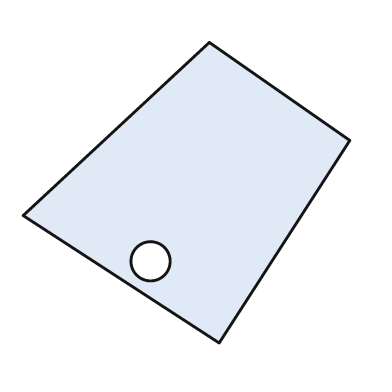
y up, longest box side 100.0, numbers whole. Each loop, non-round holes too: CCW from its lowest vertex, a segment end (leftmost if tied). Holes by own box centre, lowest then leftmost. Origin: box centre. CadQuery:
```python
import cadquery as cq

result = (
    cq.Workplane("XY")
    .moveTo(10.0, -46.0)
    .lineTo(50.0, 16.0)
    .lineTo(7.0, 46.0)
    .lineTo(-50.0, -7.0)
    .close()
    .moveTo(-11.0, -21.0)
    .circle(6.0)
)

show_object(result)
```